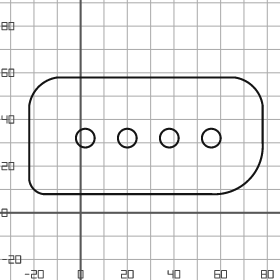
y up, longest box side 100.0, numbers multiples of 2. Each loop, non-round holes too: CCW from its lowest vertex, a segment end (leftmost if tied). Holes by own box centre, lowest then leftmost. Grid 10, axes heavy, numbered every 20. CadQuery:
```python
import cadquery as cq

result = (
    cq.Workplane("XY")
    .moveTo(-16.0, 8.0)
    .lineTo(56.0, 8.0)
    .threePointArc((72.0, 14.0), (78.0, 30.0))
    .lineTo(78.0, 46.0)
    .threePointArc((74.0, 54.0), (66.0, 58.0))
    .lineTo(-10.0, 58.0)
    .threePointArc((-18.0, 54.0), (-22.0, 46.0))
    .lineTo(-22.0, 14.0)
    .threePointArc((-20.0, 10.0), (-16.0, 8.0))
    .close()
    .moveTo(2.0, 32.0)
    .circle(4.0)
    .moveTo(20.0, 32.0)
    .circle(4.0)
    .moveTo(38.0, 32.0)
    .circle(4.0)
    .moveTo(56.0, 32.0)
    .circle(4.0)
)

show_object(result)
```